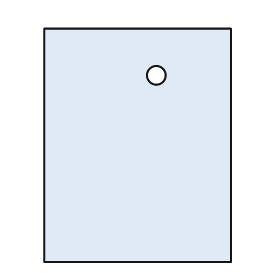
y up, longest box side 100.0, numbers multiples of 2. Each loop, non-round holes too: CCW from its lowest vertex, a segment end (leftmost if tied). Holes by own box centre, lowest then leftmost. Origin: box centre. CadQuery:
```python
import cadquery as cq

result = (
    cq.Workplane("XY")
    .moveTo(-40.0, -50.0)
    .lineTo(40.0, -50.0)
    .lineTo(40.0, 50.0)
    .lineTo(-40.0, 50.0)
    .close()
    .moveTo(8.0, 30.0)
    .circle(4.0)
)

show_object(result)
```